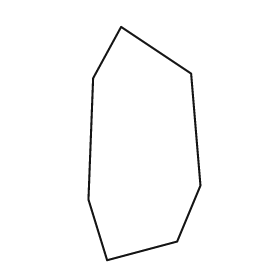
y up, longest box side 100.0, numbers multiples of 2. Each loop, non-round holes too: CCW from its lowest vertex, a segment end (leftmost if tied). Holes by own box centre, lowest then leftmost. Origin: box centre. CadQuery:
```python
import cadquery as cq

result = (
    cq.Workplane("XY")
    .moveTo(-16.0, -50.0)
    .lineTo(14.0, -42.0)
    .lineTo(24.0, -18.0)
    .lineTo(20.0, 30.0)
    .lineTo(-10.0, 50.0)
    .lineTo(-22.0, 28.0)
    .lineTo(-24.0, -24.0)
    .close()
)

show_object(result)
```